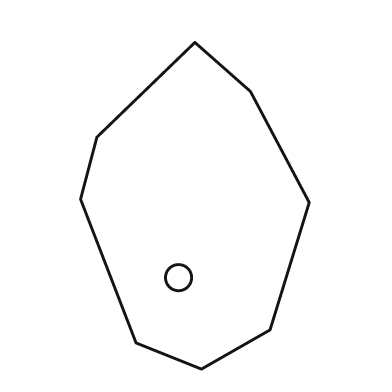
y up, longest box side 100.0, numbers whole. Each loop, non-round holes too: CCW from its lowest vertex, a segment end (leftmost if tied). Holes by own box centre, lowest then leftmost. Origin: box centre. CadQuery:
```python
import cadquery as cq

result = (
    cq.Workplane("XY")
    .moveTo(2.0, -50.0)
    .lineTo(23.0, -38.0)
    .lineTo(35.0, 1.0)
    .lineTo(17.0, 35.0)
    .lineTo(0.0, 50.0)
    .lineTo(-30.0, 21.0)
    .lineTo(-35.0, 2.0)
    .lineTo(-18.0, -42.0)
    .close()
    .moveTo(-5.0, -22.0)
    .circle(4.0)
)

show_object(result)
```